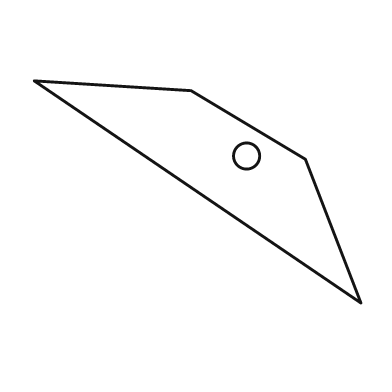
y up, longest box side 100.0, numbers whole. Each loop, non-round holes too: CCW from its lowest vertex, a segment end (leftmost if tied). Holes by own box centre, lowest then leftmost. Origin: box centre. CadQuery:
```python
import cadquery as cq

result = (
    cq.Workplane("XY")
    .moveTo(50.0, -34.0)
    .lineTo(33.0, 10.0)
    .lineTo(-2.0, 31.0)
    .lineTo(-50.0, 34.0)
    .close()
    .moveTo(15.0, 11.0)
    .circle(4.0)
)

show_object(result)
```